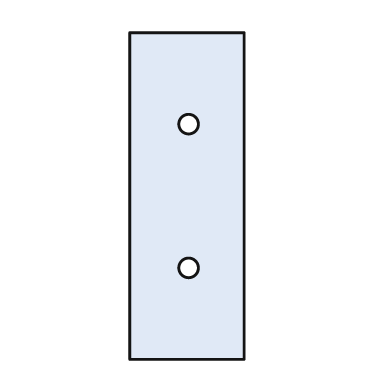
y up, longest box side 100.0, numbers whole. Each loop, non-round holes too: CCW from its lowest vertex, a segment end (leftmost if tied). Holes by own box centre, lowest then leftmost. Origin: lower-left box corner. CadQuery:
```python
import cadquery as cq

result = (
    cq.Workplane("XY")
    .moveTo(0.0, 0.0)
    .lineTo(35.0, 0.0)
    .lineTo(35.0, 100.0)
    .lineTo(0.0, 100.0)
    .close()
    .moveTo(18.0, 28.0)
    .circle(3.0)
    .moveTo(18.0, 72.0)
    .circle(3.0)
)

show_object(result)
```